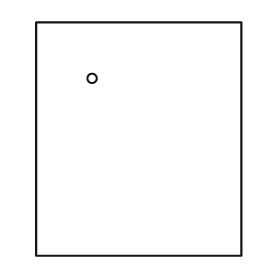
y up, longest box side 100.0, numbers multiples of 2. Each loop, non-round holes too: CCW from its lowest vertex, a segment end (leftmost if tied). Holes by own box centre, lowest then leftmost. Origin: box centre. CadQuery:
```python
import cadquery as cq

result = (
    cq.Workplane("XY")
    .moveTo(-44.0, -50.0)
    .lineTo(44.0, -50.0)
    .lineTo(44.0, 50.0)
    .lineTo(-44.0, 50.0)
    .close()
    .moveTo(-20.0, 26.0)
    .circle(2.0)
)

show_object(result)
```